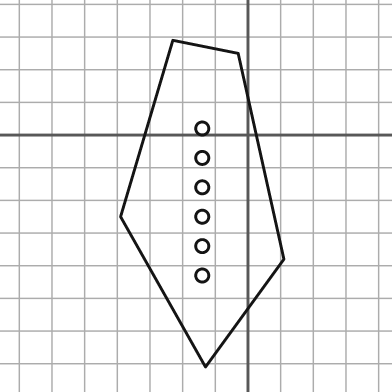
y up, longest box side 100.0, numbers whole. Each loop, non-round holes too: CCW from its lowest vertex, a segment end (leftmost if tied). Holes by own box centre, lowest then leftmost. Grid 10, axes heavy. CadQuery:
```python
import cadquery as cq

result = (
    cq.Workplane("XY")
    .moveTo(-13.0, -71.0)
    .lineTo(11.0, -38.0)
    .lineTo(-3.0, 25.0)
    .lineTo(-23.0, 29.0)
    .lineTo(-39.0, -25.0)
    .close()
    .moveTo(-14.0, -43.0)
    .circle(2.0)
    .moveTo(-14.0, -34.0)
    .circle(2.0)
    .moveTo(-14.0, -25.0)
    .circle(2.0)
    .moveTo(-14.0, -16.0)
    .circle(2.0)
    .moveTo(-14.0, -7.0)
    .circle(2.0)
    .moveTo(-14.0, 2.0)
    .circle(2.0)
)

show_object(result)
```